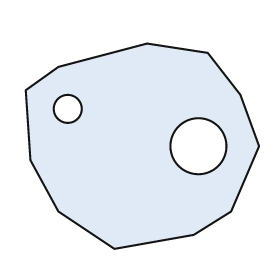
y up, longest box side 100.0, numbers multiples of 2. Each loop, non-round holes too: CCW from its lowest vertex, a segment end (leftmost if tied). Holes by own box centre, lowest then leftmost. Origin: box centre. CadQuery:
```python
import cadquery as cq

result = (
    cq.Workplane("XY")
    .moveTo(-12.0, -44.0)
    .lineTo(22.0, -38.0)
    .lineTo(38.0, -28.0)
    .lineTo(50.0, 0.0)
    .lineTo(42.0, 22.0)
    .lineTo(28.0, 40.0)
    .lineTo(2.0, 44.0)
    .lineTo(-36.0, 34.0)
    .lineTo(-50.0, 24.0)
    .lineTo(-48.0, -6.0)
    .lineTo(-36.0, -28.0)
    .close()
    .moveTo(24.0, 0.0)
    .circle(12.0)
    .moveTo(-32.0, 16.0)
    .circle(6.0)
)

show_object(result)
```